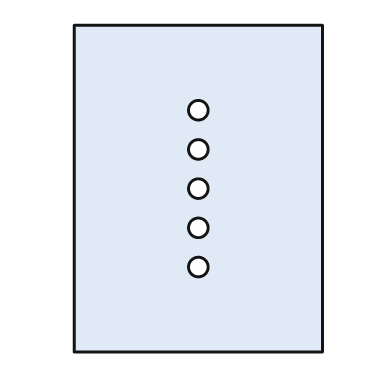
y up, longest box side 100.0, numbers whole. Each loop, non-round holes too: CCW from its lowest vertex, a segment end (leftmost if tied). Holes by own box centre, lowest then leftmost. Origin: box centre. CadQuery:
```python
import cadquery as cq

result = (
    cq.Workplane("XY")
    .moveTo(-38.0, -50.0)
    .lineTo(38.0, -50.0)
    .lineTo(38.0, 50.0)
    .lineTo(-38.0, 50.0)
    .close()
    .moveTo(0.0, -24.0)
    .circle(3.0)
    .moveTo(0.0, -12.0)
    .circle(3.0)
    .moveTo(0.0, 0.0)
    .circle(3.0)
    .moveTo(0.0, 12.0)
    .circle(3.0)
    .moveTo(0.0, 24.0)
    .circle(3.0)
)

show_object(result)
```